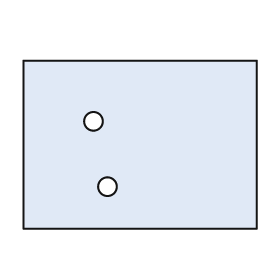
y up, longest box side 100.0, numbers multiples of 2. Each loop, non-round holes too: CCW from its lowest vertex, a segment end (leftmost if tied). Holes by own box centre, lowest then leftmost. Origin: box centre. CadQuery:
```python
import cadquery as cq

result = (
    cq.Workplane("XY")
    .moveTo(-50.0, -36.0)
    .lineTo(50.0, -36.0)
    .lineTo(50.0, 36.0)
    .lineTo(-50.0, 36.0)
    .close()
    .moveTo(-14.0, -18.0)
    .circle(4.0)
    .moveTo(-20.0, 10.0)
    .circle(4.0)
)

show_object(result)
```